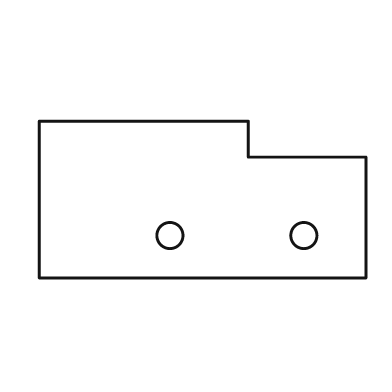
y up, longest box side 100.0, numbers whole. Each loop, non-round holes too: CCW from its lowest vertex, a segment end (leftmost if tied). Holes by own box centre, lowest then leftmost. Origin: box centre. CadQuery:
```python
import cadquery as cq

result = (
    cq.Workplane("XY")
    .moveTo(-50.0, -24.0)
    .lineTo(50.0, -24.0)
    .lineTo(50.0, 13.0)
    .lineTo(14.0, 13.0)
    .lineTo(14.0, 24.0)
    .lineTo(-50.0, 24.0)
    .close()
    .moveTo(-10.0, -11.0)
    .circle(4.0)
    .moveTo(31.0, -11.0)
    .circle(4.0)
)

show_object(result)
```